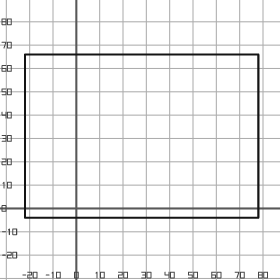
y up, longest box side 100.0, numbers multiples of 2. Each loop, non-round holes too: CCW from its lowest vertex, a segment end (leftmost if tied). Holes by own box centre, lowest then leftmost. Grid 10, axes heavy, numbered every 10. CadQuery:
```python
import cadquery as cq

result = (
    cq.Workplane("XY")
    .moveTo(-22.0, -4.0)
    .lineTo(78.0, -4.0)
    .lineTo(78.0, 66.0)
    .lineTo(-22.0, 66.0)
    .close()
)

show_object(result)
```